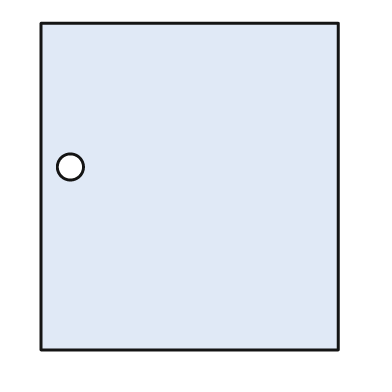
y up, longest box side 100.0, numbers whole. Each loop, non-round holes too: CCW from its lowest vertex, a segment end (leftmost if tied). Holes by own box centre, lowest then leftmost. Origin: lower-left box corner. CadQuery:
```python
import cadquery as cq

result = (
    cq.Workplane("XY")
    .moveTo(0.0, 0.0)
    .lineTo(91.0, 0.0)
    .lineTo(91.0, 100.0)
    .lineTo(0.0, 100.0)
    .close()
    .moveTo(9.0, 56.0)
    .circle(4.0)
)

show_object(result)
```